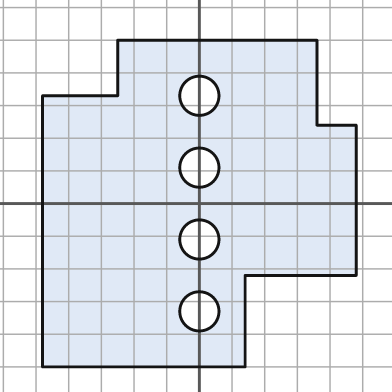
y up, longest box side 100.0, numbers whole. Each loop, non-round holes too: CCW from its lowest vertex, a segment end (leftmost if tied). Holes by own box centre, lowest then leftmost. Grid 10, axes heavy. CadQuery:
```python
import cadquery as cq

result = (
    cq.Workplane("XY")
    .moveTo(-48.0, -50.0)
    .lineTo(14.0, -50.0)
    .lineTo(14.0, -22.0)
    .lineTo(48.0, -22.0)
    .lineTo(48.0, 24.0)
    .lineTo(36.0, 24.0)
    .lineTo(36.0, 50.0)
    .lineTo(-25.0, 50.0)
    .lineTo(-25.0, 33.0)
    .lineTo(-48.0, 33.0)
    .close()
    .moveTo(0.0, -33.0)
    .circle(6.0)
    .moveTo(0.0, -11.0)
    .circle(6.0)
    .moveTo(0.0, 11.0)
    .circle(6.0)
    .moveTo(0.0, 33.0)
    .circle(6.0)
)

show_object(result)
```